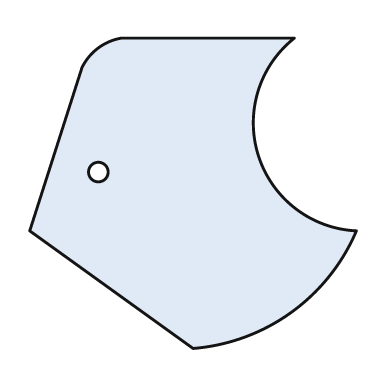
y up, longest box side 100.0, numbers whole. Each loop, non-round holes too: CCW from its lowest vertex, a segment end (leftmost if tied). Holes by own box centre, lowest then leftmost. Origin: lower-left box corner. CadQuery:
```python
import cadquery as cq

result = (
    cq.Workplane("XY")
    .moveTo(50.0, 0.0)
    .threePointArc((80.0, 11.0), (100.0, 36.0))
    .threePointArc((70.0, 59.0), (81.0, 95.0))
    .lineTo(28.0, 95.0)
    .threePointArc((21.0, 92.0), (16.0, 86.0))
    .lineTo(0.0, 36.0)
    .close()
    .moveTo(21.0, 54.0)
    .circle(3.0)
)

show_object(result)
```